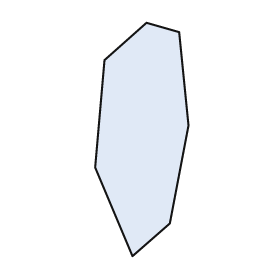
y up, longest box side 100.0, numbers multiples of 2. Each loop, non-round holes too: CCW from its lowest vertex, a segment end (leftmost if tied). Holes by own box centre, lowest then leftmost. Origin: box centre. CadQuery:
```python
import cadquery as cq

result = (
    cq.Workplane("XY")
    .moveTo(-4.0, -50.0)
    .lineTo(12.0, -36.0)
    .lineTo(20.0, 6.0)
    .lineTo(16.0, 46.0)
    .lineTo(2.0, 50.0)
    .lineTo(-16.0, 34.0)
    .lineTo(-20.0, -12.0)
    .close()
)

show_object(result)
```